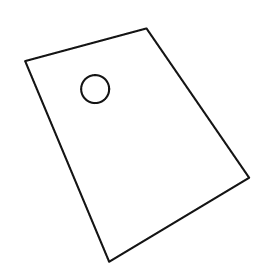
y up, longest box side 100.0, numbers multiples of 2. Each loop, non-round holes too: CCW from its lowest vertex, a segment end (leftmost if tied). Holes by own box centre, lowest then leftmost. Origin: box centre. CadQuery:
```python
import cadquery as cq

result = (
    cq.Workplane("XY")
    .moveTo(-12.0, -50.0)
    .lineTo(48.0, -14.0)
    .lineTo(4.0, 50.0)
    .lineTo(-48.0, 36.0)
    .close()
    .moveTo(-18.0, 24.0)
    .circle(6.0)
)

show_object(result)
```